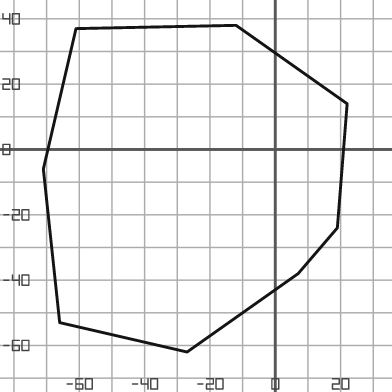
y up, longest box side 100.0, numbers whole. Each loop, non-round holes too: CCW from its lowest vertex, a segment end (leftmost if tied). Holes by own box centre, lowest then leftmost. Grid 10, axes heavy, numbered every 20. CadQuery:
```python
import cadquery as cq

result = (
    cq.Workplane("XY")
    .moveTo(-27.0, -62.0)
    .lineTo(7.0, -38.0)
    .lineTo(19.0, -24.0)
    .lineTo(22.0, 14.0)
    .lineTo(-12.0, 38.0)
    .lineTo(-61.0, 37.0)
    .lineTo(-71.0, -6.0)
    .lineTo(-66.0, -53.0)
    .close()
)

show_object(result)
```